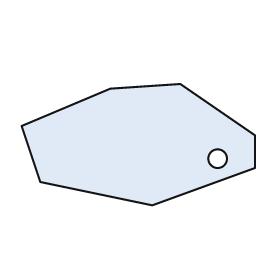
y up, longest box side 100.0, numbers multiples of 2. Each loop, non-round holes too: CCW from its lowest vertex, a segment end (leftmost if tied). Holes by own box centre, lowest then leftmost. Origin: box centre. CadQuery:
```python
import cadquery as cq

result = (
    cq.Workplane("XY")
    .moveTo(6.0, -26.0)
    .lineTo(50.0, -10.0)
    .lineTo(50.0, 4.0)
    .lineTo(18.0, 26.0)
    .lineTo(-12.0, 24.0)
    .lineTo(-50.0, 8.0)
    .lineTo(-42.0, -16.0)
    .close()
    .moveTo(34.0, -6.0)
    .circle(4.0)
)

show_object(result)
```